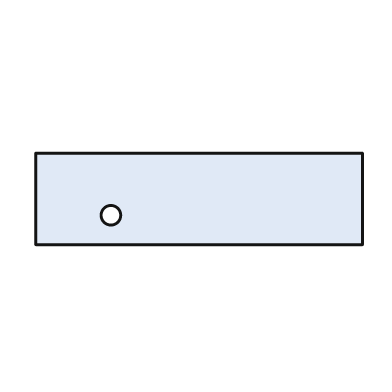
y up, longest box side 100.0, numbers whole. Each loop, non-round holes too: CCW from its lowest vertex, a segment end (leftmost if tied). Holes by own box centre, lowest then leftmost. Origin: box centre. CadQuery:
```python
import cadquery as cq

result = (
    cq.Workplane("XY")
    .moveTo(-50.0, -14.0)
    .lineTo(50.0, -14.0)
    .lineTo(50.0, 14.0)
    .lineTo(-50.0, 14.0)
    .close()
    .moveTo(-27.0, -5.0)
    .circle(3.0)
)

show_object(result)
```